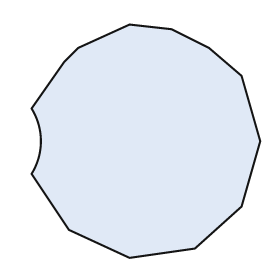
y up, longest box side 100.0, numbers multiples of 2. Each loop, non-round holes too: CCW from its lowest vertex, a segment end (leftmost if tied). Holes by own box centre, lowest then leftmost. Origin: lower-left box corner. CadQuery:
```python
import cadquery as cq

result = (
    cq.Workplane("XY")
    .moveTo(42.0, 0.0)
    .lineTo(70.0, 4.0)
    .lineTo(90.0, 22.0)
    .lineTo(98.0, 50.0)
    .lineTo(90.0, 78.0)
    .lineTo(76.0, 90.0)
    .lineTo(60.0, 98.0)
    .lineTo(42.0, 100.0)
    .lineTo(20.0, 90.0)
    .lineTo(14.0, 84.0)
    .lineTo(0.0, 64.0)
    .threePointArc((4.0, 50.0), (0.0, 36.0))
    .lineTo(16.0, 12.0)
    .close()
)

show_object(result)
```